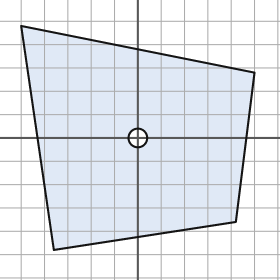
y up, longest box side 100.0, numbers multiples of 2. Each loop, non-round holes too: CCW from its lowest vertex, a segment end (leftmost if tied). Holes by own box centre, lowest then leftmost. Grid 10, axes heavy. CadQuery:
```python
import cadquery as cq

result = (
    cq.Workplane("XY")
    .moveTo(-36.0, -48.0)
    .lineTo(42.0, -36.0)
    .lineTo(50.0, 28.0)
    .lineTo(-50.0, 48.0)
    .close()
    .moveTo(0.0, 0.0)
    .circle(4.0)
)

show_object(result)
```